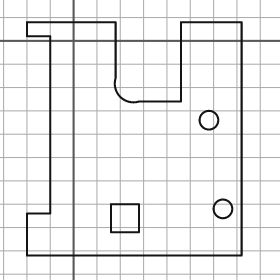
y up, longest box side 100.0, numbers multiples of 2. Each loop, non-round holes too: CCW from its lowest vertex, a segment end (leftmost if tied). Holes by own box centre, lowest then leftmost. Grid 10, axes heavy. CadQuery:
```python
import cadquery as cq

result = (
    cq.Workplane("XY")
    .moveTo(-20.0, -92.0)
    .lineTo(72.0, -92.0)
    .lineTo(72.0, 8.0)
    .lineTo(46.0, 8.0)
    .lineTo(46.0, -26.0)
    .lineTo(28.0, -26.0)
    .threePointArc((20.0, -24.0), (18.0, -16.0))
    .lineTo(18.0, 8.0)
    .lineTo(-20.0, 8.0)
    .lineTo(-20.0, 2.0)
    .lineTo(-10.0, 2.0)
    .lineTo(-10.0, -74.0)
    .lineTo(-20.0, -74.0)
    .close()
    .moveTo(16.0, -82.0)
    .lineTo(28.0, -82.0)
    .lineTo(28.0, -70.0)
    .lineTo(16.0, -70.0)
    .close()
    .moveTo(64.0, -72.0)
    .circle(4.0)
    .moveTo(58.0, -34.0)
    .circle(4.0)
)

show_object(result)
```